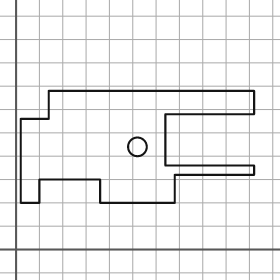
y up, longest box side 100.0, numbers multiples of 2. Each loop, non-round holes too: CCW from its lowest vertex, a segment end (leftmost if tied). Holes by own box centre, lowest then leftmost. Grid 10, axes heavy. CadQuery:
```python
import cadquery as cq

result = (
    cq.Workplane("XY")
    .moveTo(2.0, 20.0)
    .lineTo(10.0, 20.0)
    .lineTo(10.0, 30.0)
    .lineTo(36.0, 30.0)
    .lineTo(36.0, 20.0)
    .lineTo(68.0, 20.0)
    .lineTo(68.0, 32.0)
    .lineTo(102.0, 32.0)
    .lineTo(102.0, 36.0)
    .lineTo(64.0, 36.0)
    .lineTo(64.0, 58.0)
    .lineTo(102.0, 58.0)
    .lineTo(102.0, 68.0)
    .lineTo(14.0, 68.0)
    .lineTo(14.0, 56.0)
    .lineTo(2.0, 56.0)
    .close()
    .moveTo(52.0, 44.0)
    .circle(4.0)
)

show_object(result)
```